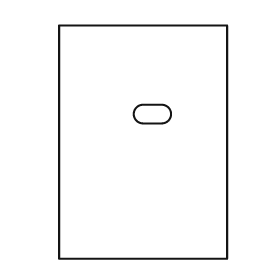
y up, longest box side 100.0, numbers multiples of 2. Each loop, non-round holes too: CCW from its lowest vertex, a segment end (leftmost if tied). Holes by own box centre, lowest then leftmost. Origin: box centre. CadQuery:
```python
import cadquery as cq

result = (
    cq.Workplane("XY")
    .moveTo(-36.0, -50.0)
    .lineTo(36.0, -50.0)
    .lineTo(36.0, 50.0)
    .lineTo(-36.0, 50.0)
    .close()
    .moveTo(0.0, 8.0)
    .lineTo(8.0, 8.0)
    .threePointArc((12.0, 12.0), (8.0, 16.0))
    .lineTo(0.0, 16.0)
    .threePointArc((-4.0, 12.0), (0.0, 8.0))
    .close()
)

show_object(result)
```